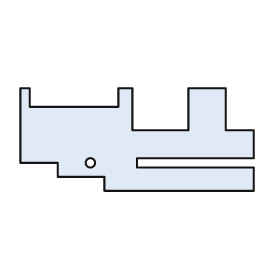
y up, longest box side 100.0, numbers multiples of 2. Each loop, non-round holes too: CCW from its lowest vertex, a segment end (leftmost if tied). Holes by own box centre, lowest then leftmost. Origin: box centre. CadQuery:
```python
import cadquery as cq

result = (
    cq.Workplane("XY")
    .moveTo(-14.0, -22.0)
    .lineTo(50.0, -22.0)
    .lineTo(50.0, -12.0)
    .lineTo(0.0, -12.0)
    .lineTo(0.0, -8.0)
    .lineTo(50.0, -8.0)
    .lineTo(50.0, 4.0)
    .lineTo(38.0, 4.0)
    .lineTo(38.0, 22.0)
    .lineTo(22.0, 22.0)
    .lineTo(22.0, 4.0)
    .lineTo(-2.0, 4.0)
    .lineTo(-2.0, 22.0)
    .lineTo(-8.0, 22.0)
    .lineTo(-8.0, 14.0)
    .lineTo(-46.0, 14.0)
    .lineTo(-46.0, 22.0)
    .lineTo(-50.0, 22.0)
    .lineTo(-50.0, -10.0)
    .lineTo(-34.0, -10.0)
    .lineTo(-34.0, -16.0)
    .lineTo(-14.0, -16.0)
    .close()
    .moveTo(-20.0, -10.0)
    .circle(2.0)
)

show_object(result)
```